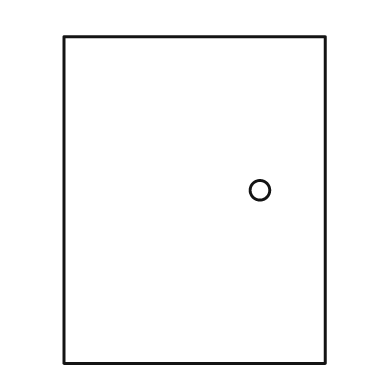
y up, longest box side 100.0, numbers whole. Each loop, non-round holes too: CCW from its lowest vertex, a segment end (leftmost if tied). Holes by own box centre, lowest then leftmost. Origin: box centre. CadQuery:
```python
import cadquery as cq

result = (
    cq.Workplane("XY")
    .moveTo(-40.0, -50.0)
    .lineTo(40.0, -50.0)
    .lineTo(40.0, 50.0)
    .lineTo(-40.0, 50.0)
    .close()
    .moveTo(20.0, 3.0)
    .circle(3.0)
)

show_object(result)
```